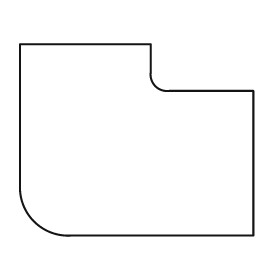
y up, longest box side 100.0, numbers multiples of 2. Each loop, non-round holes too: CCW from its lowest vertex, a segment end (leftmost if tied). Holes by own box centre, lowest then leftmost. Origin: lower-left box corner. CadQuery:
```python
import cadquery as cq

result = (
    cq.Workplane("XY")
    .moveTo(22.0, 0.0)
    .lineTo(100.0, 0.0)
    .lineTo(100.0, 62.0)
    .lineTo(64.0, 62.0)
    .threePointArc((58.0, 64.0), (56.0, 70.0))
    .lineTo(56.0, 82.0)
    .lineTo(0.0, 82.0)
    .lineTo(0.0, 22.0)
    .threePointArc((6.0, 6.0), (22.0, 0.0))
    .close()
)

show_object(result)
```